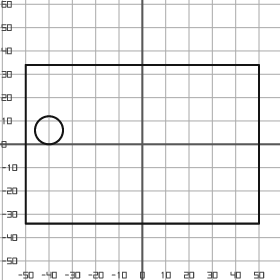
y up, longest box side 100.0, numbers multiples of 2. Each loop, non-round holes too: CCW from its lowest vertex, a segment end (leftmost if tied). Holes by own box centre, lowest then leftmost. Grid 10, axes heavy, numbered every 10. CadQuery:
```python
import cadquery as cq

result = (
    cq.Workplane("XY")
    .moveTo(-50.0, -34.0)
    .lineTo(50.0, -34.0)
    .lineTo(50.0, 34.0)
    .lineTo(-50.0, 34.0)
    .close()
    .moveTo(-40.0, 6.0)
    .circle(6.0)
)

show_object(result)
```